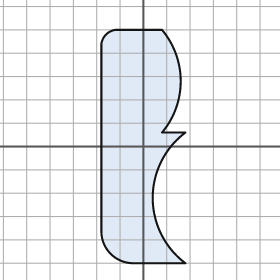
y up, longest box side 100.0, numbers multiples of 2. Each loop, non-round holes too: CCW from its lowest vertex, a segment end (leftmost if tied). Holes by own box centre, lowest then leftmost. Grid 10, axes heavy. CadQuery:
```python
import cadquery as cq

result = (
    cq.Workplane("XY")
    .moveTo(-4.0, -50.0)
    .lineTo(18.0, -50.0)
    .threePointArc((4.0, -22.0), (18.0, 6.0))
    .lineTo(8.0, 6.0)
    .threePointArc((16.0, 28.0), (8.0, 50.0))
    .lineTo(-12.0, 50.0)
    .threePointArc((-16.0, 48.0), (-18.0, 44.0))
    .lineTo(-18.0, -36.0)
    .threePointArc((-14.0, -46.0), (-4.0, -50.0))
    .close()
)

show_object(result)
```